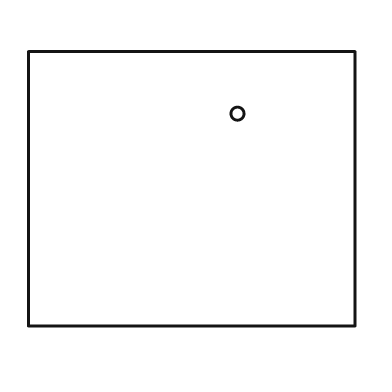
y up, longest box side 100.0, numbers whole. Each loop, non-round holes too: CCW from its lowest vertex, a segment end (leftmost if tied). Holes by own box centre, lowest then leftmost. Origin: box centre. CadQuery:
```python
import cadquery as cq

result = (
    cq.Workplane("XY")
    .moveTo(-50.0, -42.0)
    .lineTo(50.0, -42.0)
    .lineTo(50.0, 42.0)
    .lineTo(-50.0, 42.0)
    .close()
    .moveTo(14.0, 23.0)
    .circle(2.0)
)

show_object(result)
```